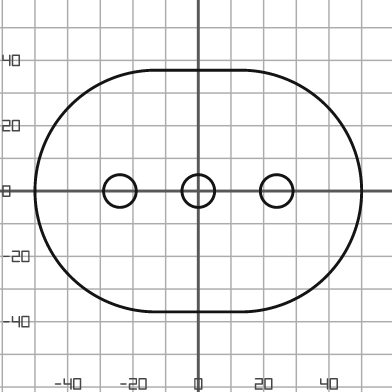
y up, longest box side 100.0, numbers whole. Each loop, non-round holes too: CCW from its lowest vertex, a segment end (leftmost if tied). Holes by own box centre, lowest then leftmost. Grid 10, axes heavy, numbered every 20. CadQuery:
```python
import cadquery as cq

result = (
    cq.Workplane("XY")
    .moveTo(-13.0, -37.0)
    .lineTo(13.0, -37.0)
    .threePointArc((50.0, 0.0), (13.0, 37.0))
    .lineTo(-13.0, 37.0)
    .threePointArc((-50.0, 0.0), (-13.0, -37.0))
    .close()
    .moveTo(-24.0, 0.0)
    .circle(5.0)
    .moveTo(0.0, 0.0)
    .circle(5.0)
    .moveTo(24.0, 0.0)
    .circle(5.0)
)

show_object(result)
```